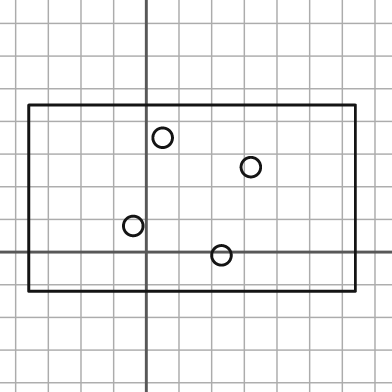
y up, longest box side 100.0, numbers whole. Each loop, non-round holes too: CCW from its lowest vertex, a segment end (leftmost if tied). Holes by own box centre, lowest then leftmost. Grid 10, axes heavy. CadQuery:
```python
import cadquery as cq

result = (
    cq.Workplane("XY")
    .moveTo(-36.0, -12.0)
    .lineTo(64.0, -12.0)
    .lineTo(64.0, 45.0)
    .lineTo(-36.0, 45.0)
    .close()
    .moveTo(23.0, -1.0)
    .circle(3.0)
    .moveTo(-4.0, 8.0)
    .circle(3.0)
    .moveTo(32.0, 26.0)
    .circle(3.0)
    .moveTo(5.0, 35.0)
    .circle(3.0)
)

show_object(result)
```